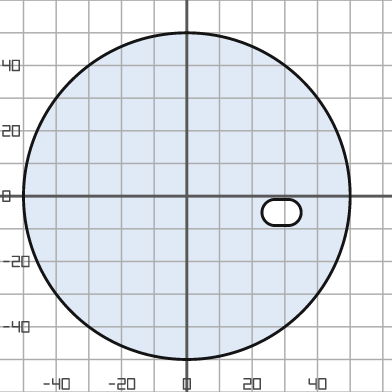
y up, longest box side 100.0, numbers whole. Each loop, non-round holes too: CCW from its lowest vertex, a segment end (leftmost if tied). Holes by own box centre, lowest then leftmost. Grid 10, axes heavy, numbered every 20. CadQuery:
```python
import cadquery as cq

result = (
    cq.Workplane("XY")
    .moveTo(0.0, 0.0)
    .circle(50.0)
    .moveTo(27.0, -9.0)
    .lineTo(31.0, -9.0)
    .threePointArc((35.0, -5.0), (31.0, -1.0))
    .lineTo(27.0, -1.0)
    .threePointArc((23.0, -5.0), (27.0, -9.0))
    .close()
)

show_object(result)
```